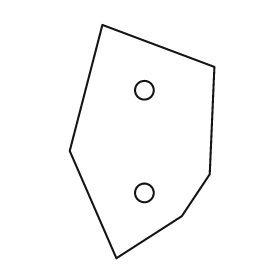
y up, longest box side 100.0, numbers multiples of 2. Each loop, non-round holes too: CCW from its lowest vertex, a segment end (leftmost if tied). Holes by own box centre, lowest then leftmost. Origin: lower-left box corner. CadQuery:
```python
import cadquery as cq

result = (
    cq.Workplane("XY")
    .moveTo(20.0, 0.0)
    .lineTo(48.0, 18.0)
    .lineTo(60.0, 36.0)
    .lineTo(62.0, 82.0)
    .lineTo(14.0, 100.0)
    .lineTo(0.0, 46.0)
    .close()
    .moveTo(32.0, 28.0)
    .circle(4.0)
    .moveTo(32.0, 72.0)
    .circle(4.0)
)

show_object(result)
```